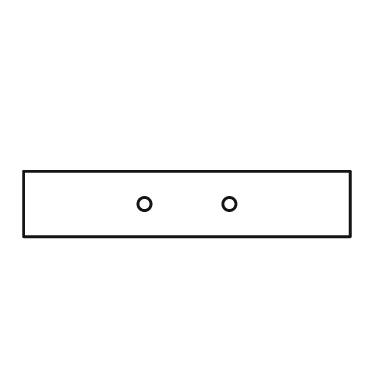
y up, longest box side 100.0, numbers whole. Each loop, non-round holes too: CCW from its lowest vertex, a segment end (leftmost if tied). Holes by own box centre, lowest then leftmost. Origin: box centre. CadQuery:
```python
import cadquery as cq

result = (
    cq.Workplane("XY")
    .moveTo(-50.0, -10.0)
    .lineTo(50.0, -10.0)
    .lineTo(50.0, 10.0)
    .lineTo(-50.0, 10.0)
    .close()
    .moveTo(-13.0, 0.0)
    .circle(2.0)
    .moveTo(13.0, 0.0)
    .circle(2.0)
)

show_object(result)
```